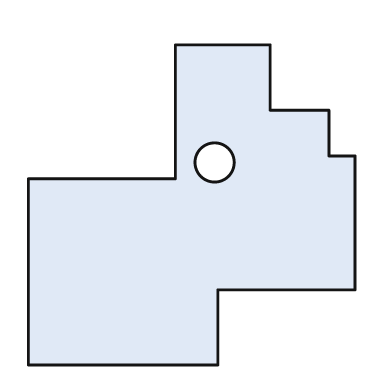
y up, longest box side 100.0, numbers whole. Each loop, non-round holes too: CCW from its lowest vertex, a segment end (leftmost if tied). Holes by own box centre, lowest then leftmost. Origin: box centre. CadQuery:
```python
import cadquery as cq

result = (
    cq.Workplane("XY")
    .moveTo(-50.0, -49.0)
    .lineTo(8.0, -49.0)
    .lineTo(8.0, -26.0)
    .lineTo(50.0, -26.0)
    .lineTo(50.0, 15.0)
    .lineTo(42.0, 15.0)
    .lineTo(42.0, 29.0)
    .lineTo(24.0, 29.0)
    .lineTo(24.0, 49.0)
    .lineTo(-5.0, 49.0)
    .lineTo(-5.0, 8.0)
    .lineTo(-50.0, 8.0)
    .close()
    .moveTo(7.0, 13.0)
    .circle(6.0)
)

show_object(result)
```